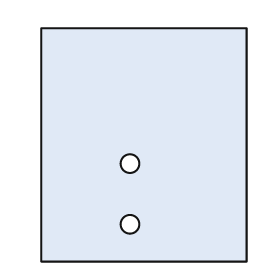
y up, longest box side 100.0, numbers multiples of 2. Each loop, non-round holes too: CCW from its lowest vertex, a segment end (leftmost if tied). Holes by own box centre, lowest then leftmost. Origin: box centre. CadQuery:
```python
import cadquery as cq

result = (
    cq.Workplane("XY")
    .moveTo(-44.0, -50.0)
    .lineTo(44.0, -50.0)
    .lineTo(44.0, 50.0)
    .lineTo(-44.0, 50.0)
    .close()
    .moveTo(-6.0, -34.0)
    .circle(4.0)
    .moveTo(-6.0, -8.0)
    .circle(4.0)
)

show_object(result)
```